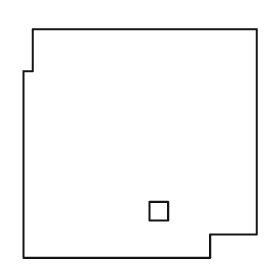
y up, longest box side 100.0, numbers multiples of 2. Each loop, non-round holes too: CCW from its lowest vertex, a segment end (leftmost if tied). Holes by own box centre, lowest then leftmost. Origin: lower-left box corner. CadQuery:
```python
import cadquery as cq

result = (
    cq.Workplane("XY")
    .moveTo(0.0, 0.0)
    .lineTo(80.0, 0.0)
    .lineTo(80.0, 10.0)
    .lineTo(100.0, 10.0)
    .lineTo(100.0, 98.0)
    .lineTo(4.0, 98.0)
    .lineTo(4.0, 80.0)
    .lineTo(0.0, 80.0)
    .close()
    .moveTo(54.0, 16.0)
    .lineTo(62.0, 16.0)
    .lineTo(62.0, 24.0)
    .lineTo(54.0, 24.0)
    .close()
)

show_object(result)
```